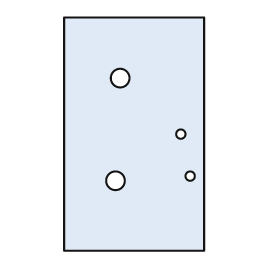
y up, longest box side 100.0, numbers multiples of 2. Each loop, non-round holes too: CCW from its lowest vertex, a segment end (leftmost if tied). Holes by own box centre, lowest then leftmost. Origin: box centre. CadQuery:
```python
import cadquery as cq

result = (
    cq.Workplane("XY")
    .moveTo(-30.0, -50.0)
    .lineTo(30.0, -50.0)
    .lineTo(30.0, 50.0)
    .lineTo(-30.0, 50.0)
    .close()
    .moveTo(-8.0, -20.0)
    .circle(4.0)
    .moveTo(24.0, -18.0)
    .circle(2.0)
    .moveTo(20.0, 0.0)
    .circle(2.0)
    .moveTo(-6.0, 24.0)
    .circle(4.0)
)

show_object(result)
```